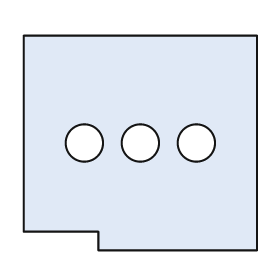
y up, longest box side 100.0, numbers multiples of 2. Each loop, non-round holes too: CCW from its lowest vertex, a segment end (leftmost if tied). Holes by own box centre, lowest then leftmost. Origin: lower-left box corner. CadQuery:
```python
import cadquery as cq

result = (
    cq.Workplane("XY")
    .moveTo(32.0, 0.0)
    .lineTo(100.0, 0.0)
    .lineTo(100.0, 92.0)
    .lineTo(0.0, 92.0)
    .lineTo(0.0, 8.0)
    .lineTo(32.0, 8.0)
    .close()
    .moveTo(26.0, 46.0)
    .circle(8.0)
    .moveTo(50.0, 46.0)
    .circle(8.0)
    .moveTo(74.0, 46.0)
    .circle(8.0)
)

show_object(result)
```